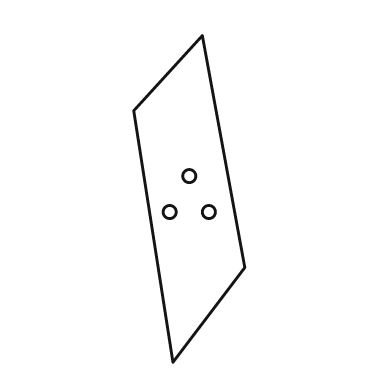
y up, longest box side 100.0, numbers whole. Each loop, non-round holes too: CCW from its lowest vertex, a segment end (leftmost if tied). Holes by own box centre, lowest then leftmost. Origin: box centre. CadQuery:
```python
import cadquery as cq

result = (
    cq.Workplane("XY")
    .moveTo(-5.0, -50.0)
    .lineTo(17.0, -21.0)
    .lineTo(4.0, 50.0)
    .lineTo(-17.0, 27.0)
    .close()
    .moveTo(-6.0, -4.0)
    .circle(2.0)
    .moveTo(6.0, -4.0)
    .circle(2.0)
    .moveTo(0.0, 7.0)
    .circle(2.0)
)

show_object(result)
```